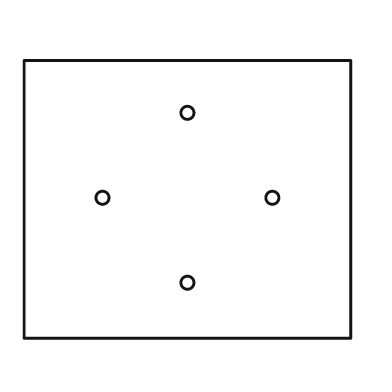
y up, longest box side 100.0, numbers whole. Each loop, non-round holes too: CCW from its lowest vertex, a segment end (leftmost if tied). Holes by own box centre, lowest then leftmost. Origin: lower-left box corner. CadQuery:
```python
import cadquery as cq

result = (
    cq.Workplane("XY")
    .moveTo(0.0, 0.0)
    .lineTo(100.0, 0.0)
    .lineTo(100.0, 85.0)
    .lineTo(0.0, 85.0)
    .close()
    .moveTo(50.0, 17.0)
    .circle(2.0)
    .moveTo(24.0, 43.0)
    .circle(2.0)
    .moveTo(76.0, 43.0)
    .circle(2.0)
    .moveTo(50.0, 69.0)
    .circle(2.0)
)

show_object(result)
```